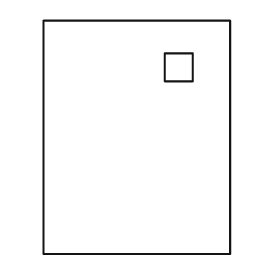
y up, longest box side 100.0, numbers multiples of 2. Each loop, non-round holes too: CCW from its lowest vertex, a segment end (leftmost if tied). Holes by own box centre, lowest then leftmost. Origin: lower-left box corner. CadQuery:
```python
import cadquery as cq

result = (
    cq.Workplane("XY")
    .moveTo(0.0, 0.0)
    .lineTo(80.0, 0.0)
    .lineTo(80.0, 100.0)
    .lineTo(0.0, 100.0)
    .close()
    .moveTo(52.0, 74.0)
    .lineTo(64.0, 74.0)
    .lineTo(64.0, 86.0)
    .lineTo(52.0, 86.0)
    .close()
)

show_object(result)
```